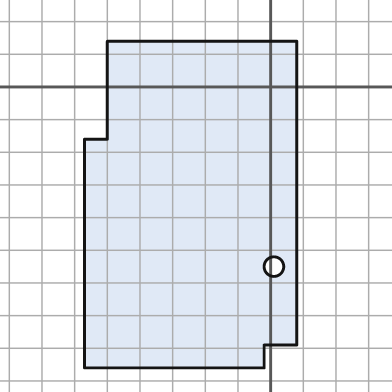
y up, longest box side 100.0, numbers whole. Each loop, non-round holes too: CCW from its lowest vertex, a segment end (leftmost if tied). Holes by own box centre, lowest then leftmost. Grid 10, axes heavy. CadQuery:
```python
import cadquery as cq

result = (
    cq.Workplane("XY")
    .moveTo(-57.0, -86.0)
    .lineTo(-2.0, -86.0)
    .lineTo(-2.0, -79.0)
    .lineTo(8.0, -79.0)
    .lineTo(8.0, 14.0)
    .lineTo(-50.0, 14.0)
    .lineTo(-50.0, -16.0)
    .lineTo(-57.0, -16.0)
    .close()
    .moveTo(1.0, -55.0)
    .circle(3.0)
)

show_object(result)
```